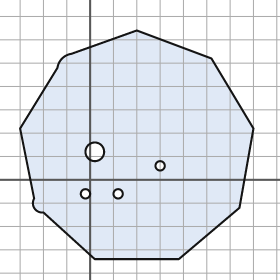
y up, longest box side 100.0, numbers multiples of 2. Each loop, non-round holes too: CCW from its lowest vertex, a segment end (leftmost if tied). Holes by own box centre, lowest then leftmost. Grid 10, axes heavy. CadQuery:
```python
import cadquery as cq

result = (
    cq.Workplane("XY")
    .moveTo(2.0, -34.0)
    .lineTo(38.0, -34.0)
    .lineTo(64.0, -12.0)
    .lineTo(70.0, 22.0)
    .lineTo(52.0, 52.0)
    .lineTo(20.0, 64.0)
    .lineTo(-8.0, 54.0)
    .threePointArc((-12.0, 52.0), (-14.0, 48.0))
    .lineTo(-30.0, 22.0)
    .lineTo(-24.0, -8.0)
    .threePointArc((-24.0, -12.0), (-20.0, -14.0))
    .close()
    .moveTo(-2.0, -6.0)
    .circle(2.0)
    .moveTo(12.0, -6.0)
    .circle(2.0)
    .moveTo(30.0, 6.0)
    .circle(2.0)
    .moveTo(2.0, 12.0)
    .circle(4.0)
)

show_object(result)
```